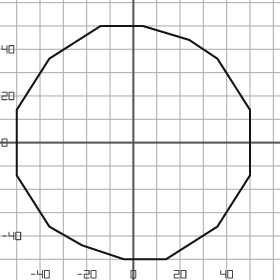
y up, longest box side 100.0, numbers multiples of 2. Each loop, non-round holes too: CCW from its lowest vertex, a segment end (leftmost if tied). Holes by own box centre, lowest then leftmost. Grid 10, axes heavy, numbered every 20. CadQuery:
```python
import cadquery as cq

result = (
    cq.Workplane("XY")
    .moveTo(-4.0, -50.0)
    .lineTo(14.0, -50.0)
    .lineTo(36.0, -36.0)
    .lineTo(50.0, -14.0)
    .lineTo(50.0, 14.0)
    .lineTo(36.0, 36.0)
    .lineTo(24.0, 44.0)
    .lineTo(4.0, 50.0)
    .lineTo(-14.0, 50.0)
    .lineTo(-36.0, 36.0)
    .lineTo(-50.0, 14.0)
    .lineTo(-50.0, -14.0)
    .lineTo(-36.0, -36.0)
    .lineTo(-22.0, -44.0)
    .close()
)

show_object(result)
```